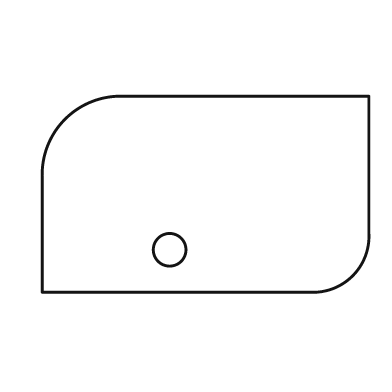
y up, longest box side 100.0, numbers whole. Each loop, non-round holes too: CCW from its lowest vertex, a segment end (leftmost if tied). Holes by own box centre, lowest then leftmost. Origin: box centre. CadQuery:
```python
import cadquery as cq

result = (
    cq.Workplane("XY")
    .moveTo(-50.0, -30.0)
    .lineTo(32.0, -30.0)
    .threePointArc((45.0, -25.0), (50.0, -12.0))
    .lineTo(50.0, 30.0)
    .lineTo(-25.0, 30.0)
    .threePointArc((-43.0, 23.0), (-50.0, 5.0))
    .close()
    .moveTo(-11.0, -17.0)
    .circle(5.0)
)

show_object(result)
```